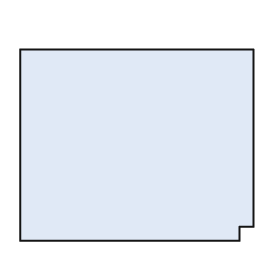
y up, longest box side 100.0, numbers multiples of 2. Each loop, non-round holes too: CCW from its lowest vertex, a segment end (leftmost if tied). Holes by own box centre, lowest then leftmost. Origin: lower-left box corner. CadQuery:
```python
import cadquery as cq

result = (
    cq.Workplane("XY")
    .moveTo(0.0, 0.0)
    .lineTo(94.0, 0.0)
    .lineTo(94.0, 6.0)
    .lineTo(100.0, 6.0)
    .lineTo(100.0, 82.0)
    .lineTo(0.0, 82.0)
    .close()
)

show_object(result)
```